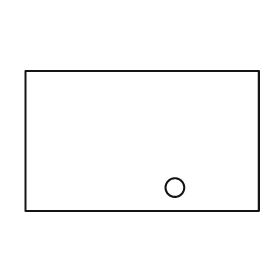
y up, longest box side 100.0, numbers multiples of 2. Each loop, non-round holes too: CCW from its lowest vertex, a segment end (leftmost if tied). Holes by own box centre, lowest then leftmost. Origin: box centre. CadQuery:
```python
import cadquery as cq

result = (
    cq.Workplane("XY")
    .moveTo(-50.0, -30.0)
    .lineTo(50.0, -30.0)
    .lineTo(50.0, 30.0)
    .lineTo(-50.0, 30.0)
    .close()
    .moveTo(14.0, -20.0)
    .circle(4.0)
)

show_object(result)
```